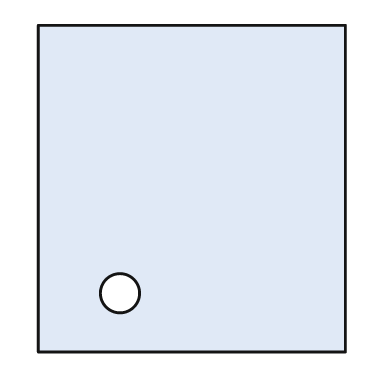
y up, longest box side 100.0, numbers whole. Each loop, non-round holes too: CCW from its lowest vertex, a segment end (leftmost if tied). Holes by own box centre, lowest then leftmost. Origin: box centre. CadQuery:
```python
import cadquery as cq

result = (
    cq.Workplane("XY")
    .moveTo(-47.0, -50.0)
    .lineTo(47.0, -50.0)
    .lineTo(47.0, 50.0)
    .lineTo(-47.0, 50.0)
    .close()
    .moveTo(-22.0, -32.0)
    .circle(6.0)
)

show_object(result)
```